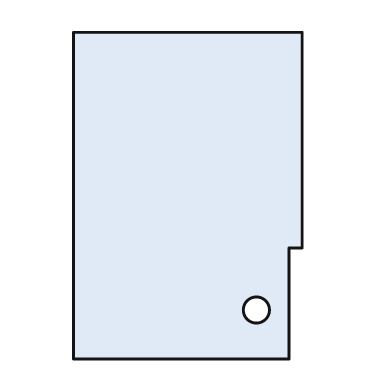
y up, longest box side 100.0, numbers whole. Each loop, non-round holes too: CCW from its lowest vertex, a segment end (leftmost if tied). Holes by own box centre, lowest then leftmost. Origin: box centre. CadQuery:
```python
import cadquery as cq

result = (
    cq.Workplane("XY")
    .moveTo(-35.0, -50.0)
    .lineTo(31.0, -50.0)
    .lineTo(31.0, -16.0)
    .lineTo(35.0, -16.0)
    .lineTo(35.0, 50.0)
    .lineTo(-35.0, 50.0)
    .close()
    .moveTo(21.0, -35.0)
    .circle(4.0)
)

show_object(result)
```